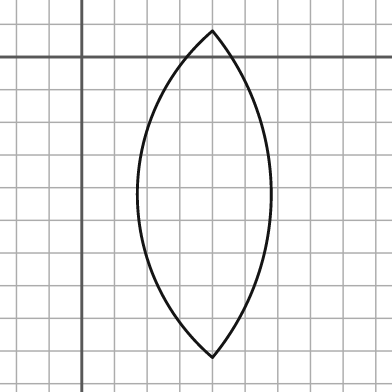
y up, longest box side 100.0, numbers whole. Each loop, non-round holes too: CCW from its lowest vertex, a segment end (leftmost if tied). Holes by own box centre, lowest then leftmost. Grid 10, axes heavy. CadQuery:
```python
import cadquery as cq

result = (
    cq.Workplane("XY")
    .moveTo(40.0, -92.0)
    .threePointArc((58.0, -42.0), (40.0, 8.0))
    .threePointArc((17.0, -42.0), (40.0, -92.0))
    .close()
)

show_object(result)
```